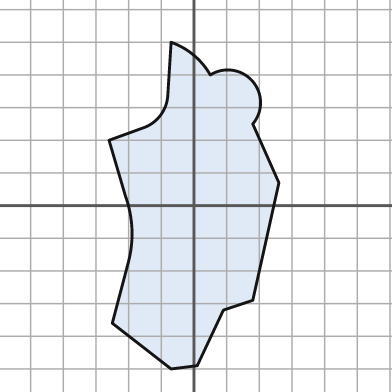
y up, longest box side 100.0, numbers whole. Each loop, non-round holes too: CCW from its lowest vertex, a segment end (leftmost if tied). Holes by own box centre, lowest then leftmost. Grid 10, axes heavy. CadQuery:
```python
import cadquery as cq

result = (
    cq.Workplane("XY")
    .moveTo(-7.0, -50.0)
    .lineTo(1.0, -49.0)
    .lineTo(9.0, -32.0)
    .lineTo(18.0, -29.0)
    .lineTo(26.0, 7.0)
    .lineTo(18.0, 25.0)
    .threePointArc((18.0, 38.0), (5.0, 40.0))
    .threePointArc((0.0, 46.0), (-7.0, 50.0))
    .lineTo(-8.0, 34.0)
    .threePointArc((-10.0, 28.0), (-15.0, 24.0))
    .lineTo(-26.0, 20.0)
    .lineTo(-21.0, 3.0)
    .threePointArc((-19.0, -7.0), (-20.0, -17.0))
    .lineTo(-25.0, -36.0)
    .close()
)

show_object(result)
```